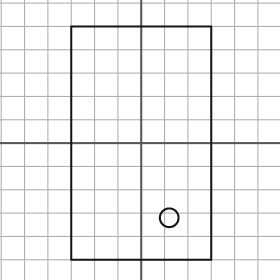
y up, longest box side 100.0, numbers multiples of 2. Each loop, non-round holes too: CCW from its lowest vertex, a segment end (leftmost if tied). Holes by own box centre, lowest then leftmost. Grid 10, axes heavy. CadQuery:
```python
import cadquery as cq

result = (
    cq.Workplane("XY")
    .moveTo(-30.0, -50.0)
    .lineTo(30.0, -50.0)
    .lineTo(30.0, 50.0)
    .lineTo(-30.0, 50.0)
    .close()
    .moveTo(12.0, -32.0)
    .circle(4.0)
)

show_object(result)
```